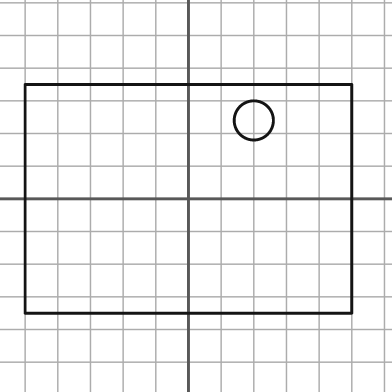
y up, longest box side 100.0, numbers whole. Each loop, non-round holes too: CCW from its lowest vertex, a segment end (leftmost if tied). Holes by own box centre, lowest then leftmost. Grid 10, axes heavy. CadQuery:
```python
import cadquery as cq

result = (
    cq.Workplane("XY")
    .moveTo(-50.0, -35.0)
    .lineTo(50.0, -35.0)
    .lineTo(50.0, 35.0)
    .lineTo(-50.0, 35.0)
    .close()
    .moveTo(20.0, 24.0)
    .circle(6.0)
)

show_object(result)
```